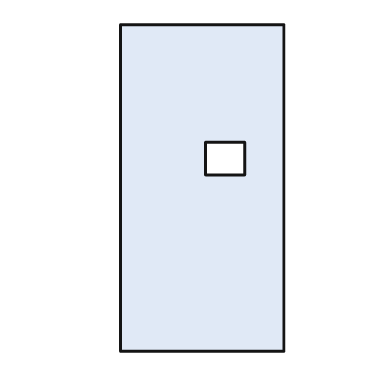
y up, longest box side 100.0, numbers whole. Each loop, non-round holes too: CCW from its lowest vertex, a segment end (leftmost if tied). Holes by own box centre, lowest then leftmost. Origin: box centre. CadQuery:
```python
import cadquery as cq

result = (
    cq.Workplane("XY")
    .moveTo(-25.0, -50.0)
    .lineTo(25.0, -50.0)
    .lineTo(25.0, 50.0)
    .lineTo(-25.0, 50.0)
    .close()
    .moveTo(1.0, 4.0)
    .lineTo(13.0, 4.0)
    .lineTo(13.0, 14.0)
    .lineTo(1.0, 14.0)
    .close()
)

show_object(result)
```